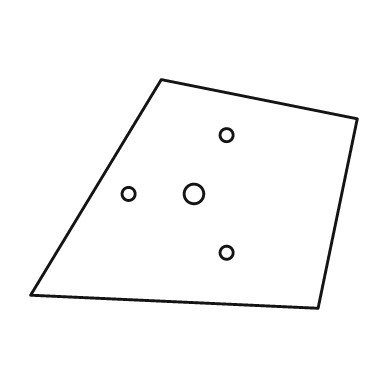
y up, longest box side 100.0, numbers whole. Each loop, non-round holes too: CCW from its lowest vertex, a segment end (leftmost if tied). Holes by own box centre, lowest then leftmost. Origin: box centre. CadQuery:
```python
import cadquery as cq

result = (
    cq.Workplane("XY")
    .moveTo(38.0, -35.0)
    .lineTo(50.0, 23.0)
    .lineTo(-10.0, 35.0)
    .lineTo(-50.0, -31.0)
    .close()
    .moveTo(10.0, -18.0)
    .circle(2.0)
    .moveTo(-20.0, 0.0)
    .circle(2.0)
    .moveTo(0.0, 0.0)
    .circle(3.0)
    .moveTo(10.0, 18.0)
    .circle(2.0)
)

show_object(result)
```